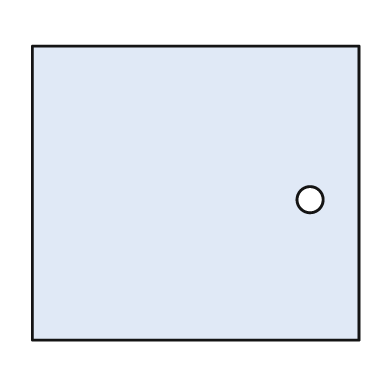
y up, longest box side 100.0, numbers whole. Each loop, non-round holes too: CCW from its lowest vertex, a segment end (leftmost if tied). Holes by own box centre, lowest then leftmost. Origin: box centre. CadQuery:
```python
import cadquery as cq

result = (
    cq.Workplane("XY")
    .moveTo(-50.0, -45.0)
    .lineTo(50.0, -45.0)
    .lineTo(50.0, 45.0)
    .lineTo(-50.0, 45.0)
    .close()
    .moveTo(35.0, -2.0)
    .circle(4.0)
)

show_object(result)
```